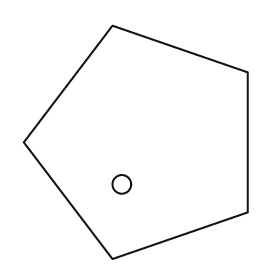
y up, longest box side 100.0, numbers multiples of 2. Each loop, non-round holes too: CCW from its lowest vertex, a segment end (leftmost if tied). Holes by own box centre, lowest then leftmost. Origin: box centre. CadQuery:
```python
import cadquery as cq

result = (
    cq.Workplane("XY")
    .moveTo(-10.0, -50.0)
    .lineTo(48.0, -30.0)
    .lineTo(48.0, 30.0)
    .lineTo(-10.0, 50.0)
    .lineTo(-48.0, 0.0)
    .close()
    .moveTo(-6.0, -18.0)
    .circle(4.0)
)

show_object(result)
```